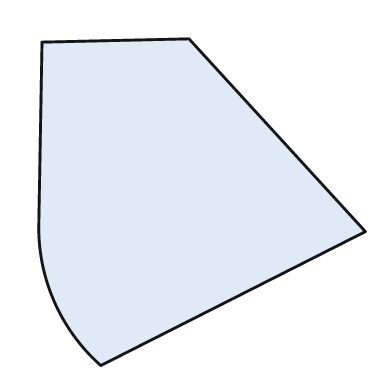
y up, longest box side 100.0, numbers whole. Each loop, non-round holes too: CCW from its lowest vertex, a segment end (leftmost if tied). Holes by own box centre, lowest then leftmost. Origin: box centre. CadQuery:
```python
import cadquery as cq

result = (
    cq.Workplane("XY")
    .moveTo(-31.0, -50.0)
    .lineTo(50.0, -9.0)
    .lineTo(-4.0, 50.0)
    .lineTo(-49.0, 49.0)
    .lineTo(-50.0, -8.0)
    .threePointArc((-45.0, -31.0), (-31.0, -50.0))
    .close()
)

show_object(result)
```